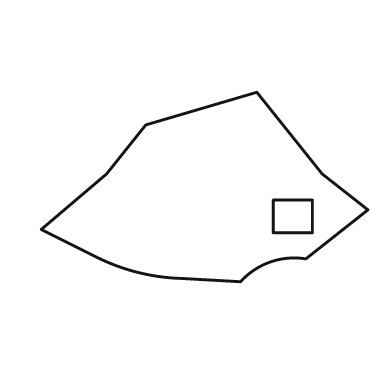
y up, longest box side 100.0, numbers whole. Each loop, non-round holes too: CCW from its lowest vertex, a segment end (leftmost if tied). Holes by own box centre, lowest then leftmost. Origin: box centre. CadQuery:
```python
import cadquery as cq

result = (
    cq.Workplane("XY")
    .moveTo(11.0, -29.0)
    .threePointArc((20.0, -23.0), (31.0, -22.0))
    .lineTo(50.0, -7.0)
    .lineTo(36.0, 4.0)
    .lineTo(16.0, 29.0)
    .lineTo(-18.0, 19.0)
    .lineTo(-30.0, 4.0)
    .lineTo(-50.0, -13.0)
    .lineTo(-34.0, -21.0)
    .threePointArc((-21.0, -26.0), (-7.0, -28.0))
    .close()
    .moveTo(21.0, -14.0)
    .lineTo(33.0, -14.0)
    .lineTo(33.0, -4.0)
    .lineTo(21.0, -4.0)
    .close()
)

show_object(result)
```